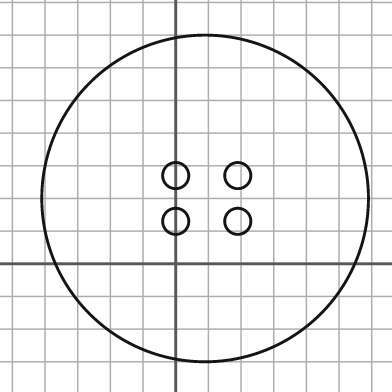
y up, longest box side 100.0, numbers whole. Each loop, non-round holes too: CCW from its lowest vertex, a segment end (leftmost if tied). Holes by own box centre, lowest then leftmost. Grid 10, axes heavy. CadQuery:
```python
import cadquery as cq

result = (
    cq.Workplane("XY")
    .moveTo(9.0, 20.0)
    .circle(50.0)
    .moveTo(0.0, 13.0)
    .circle(4.0)
    .moveTo(19.0, 13.0)
    .circle(4.0)
    .moveTo(0.0, 27.0)
    .circle(4.0)
    .moveTo(19.0, 27.0)
    .circle(4.0)
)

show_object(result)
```